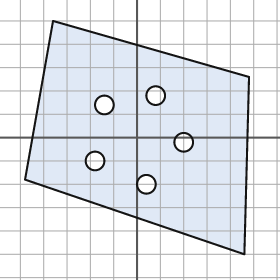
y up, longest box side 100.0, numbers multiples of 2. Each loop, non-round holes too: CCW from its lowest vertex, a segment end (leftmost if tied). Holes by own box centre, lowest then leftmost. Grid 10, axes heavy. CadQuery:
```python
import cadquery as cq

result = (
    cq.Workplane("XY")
    .moveTo(46.0, -50.0)
    .lineTo(48.0, 26.0)
    .lineTo(-36.0, 50.0)
    .lineTo(-48.0, -18.0)
    .close()
    .moveTo(4.0, -20.0)
    .circle(4.0)
    .moveTo(-18.0, -10.0)
    .circle(4.0)
    .moveTo(20.0, -2.0)
    .circle(4.0)
    .moveTo(-14.0, 14.0)
    .circle(4.0)
    .moveTo(8.0, 18.0)
    .circle(4.0)
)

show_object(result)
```